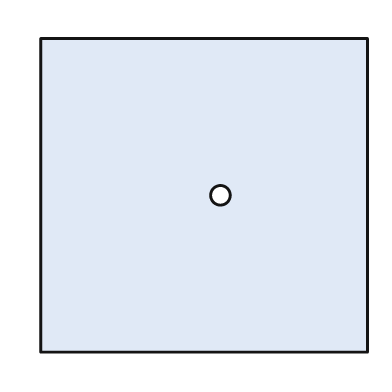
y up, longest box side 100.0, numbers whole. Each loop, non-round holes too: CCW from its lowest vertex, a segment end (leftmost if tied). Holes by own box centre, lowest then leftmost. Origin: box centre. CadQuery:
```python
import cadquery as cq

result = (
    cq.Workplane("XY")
    .moveTo(-50.0, -48.0)
    .lineTo(50.0, -48.0)
    .lineTo(50.0, 48.0)
    .lineTo(-50.0, 48.0)
    .close()
    .moveTo(5.0, 0.0)
    .circle(3.0)
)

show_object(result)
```